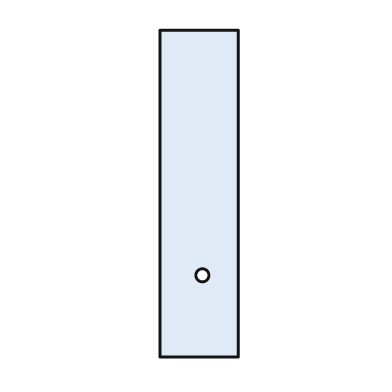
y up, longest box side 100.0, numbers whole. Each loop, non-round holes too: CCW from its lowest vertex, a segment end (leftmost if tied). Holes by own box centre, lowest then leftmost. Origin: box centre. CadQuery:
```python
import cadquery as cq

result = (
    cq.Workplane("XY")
    .moveTo(-12.0, -50.0)
    .lineTo(12.0, -50.0)
    .lineTo(12.0, 50.0)
    .lineTo(-12.0, 50.0)
    .close()
    .moveTo(1.0, -25.0)
    .circle(2.0)
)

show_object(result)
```